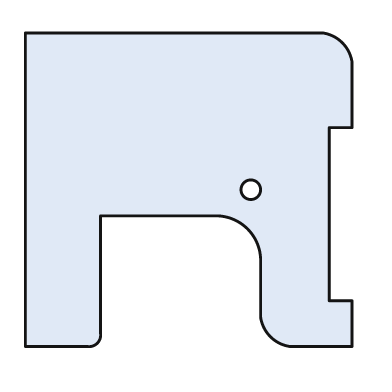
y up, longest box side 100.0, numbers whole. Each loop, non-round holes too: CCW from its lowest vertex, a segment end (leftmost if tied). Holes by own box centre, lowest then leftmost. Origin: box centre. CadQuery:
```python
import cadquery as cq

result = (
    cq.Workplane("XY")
    .moveTo(-50.0, -48.0)
    .lineTo(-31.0, -48.0)
    .threePointArc((-28.0, -47.0), (-27.0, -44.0))
    .lineTo(-27.0, -8.0)
    .lineTo(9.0, -8.0)
    .threePointArc((18.0, -12.0), (22.0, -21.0))
    .lineTo(22.0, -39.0)
    .threePointArc((25.0, -45.0), (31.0, -48.0))
    .lineTo(50.0, -48.0)
    .lineTo(50.0, -34.0)
    .lineTo(43.0, -34.0)
    .lineTo(43.0, 19.0)
    .lineTo(50.0, 19.0)
    .lineTo(50.0, 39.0)
    .threePointArc((47.0, 45.0), (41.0, 48.0))
    .lineTo(-50.0, 48.0)
    .close()
    .moveTo(19.0, 0.0)
    .circle(3.0)
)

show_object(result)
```